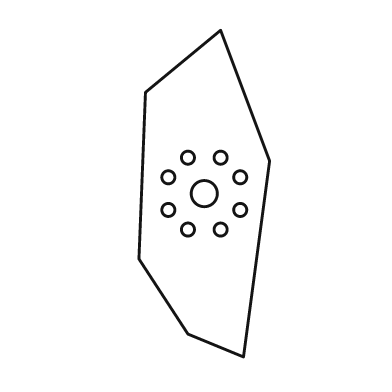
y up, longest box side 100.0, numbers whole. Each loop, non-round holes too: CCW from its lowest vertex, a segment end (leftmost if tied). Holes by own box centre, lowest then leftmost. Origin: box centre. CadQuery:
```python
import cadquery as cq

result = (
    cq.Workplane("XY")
    .moveTo(12.0, -50.0)
    .lineTo(20.0, 10.0)
    .lineTo(5.0, 50.0)
    .lineTo(-18.0, 31.0)
    .lineTo(-20.0, -20.0)
    .lineTo(-5.0, -43.0)
    .close()
    .moveTo(-5.0, -11.0)
    .circle(2.0)
    .moveTo(5.0, -11.0)
    .circle(2.0)
    .moveTo(-11.0, -5.0)
    .circle(2.0)
    .moveTo(11.0, -5.0)
    .circle(2.0)
    .moveTo(0.0, 0.0)
    .circle(4.0)
    .moveTo(-11.0, 5.0)
    .circle(2.0)
    .moveTo(11.0, 5.0)
    .circle(2.0)
    .moveTo(-5.0, 11.0)
    .circle(2.0)
    .moveTo(5.0, 11.0)
    .circle(2.0)
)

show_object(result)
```